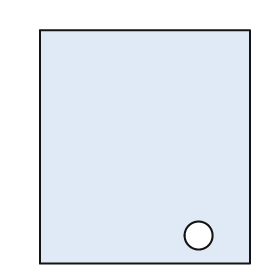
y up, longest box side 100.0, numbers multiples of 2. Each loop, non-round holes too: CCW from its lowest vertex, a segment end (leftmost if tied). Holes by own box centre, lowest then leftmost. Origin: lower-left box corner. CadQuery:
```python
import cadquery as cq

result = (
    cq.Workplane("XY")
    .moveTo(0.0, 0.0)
    .lineTo(90.0, 0.0)
    .lineTo(90.0, 100.0)
    .lineTo(0.0, 100.0)
    .close()
    .moveTo(68.0, 12.0)
    .circle(6.0)
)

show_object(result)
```